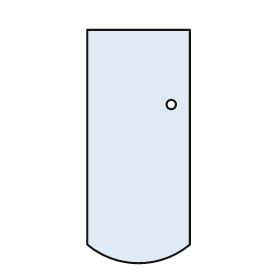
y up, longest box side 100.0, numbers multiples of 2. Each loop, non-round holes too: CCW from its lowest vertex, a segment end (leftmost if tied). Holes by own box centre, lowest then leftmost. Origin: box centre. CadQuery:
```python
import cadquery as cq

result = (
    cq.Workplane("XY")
    .moveTo(-22.0, -42.0)
    .threePointArc((0.0, -50.0), (22.0, -42.0))
    .lineTo(22.0, 50.0)
    .lineTo(-22.0, 50.0)
    .close()
    .moveTo(14.0, 18.0)
    .circle(2.0)
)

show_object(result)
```